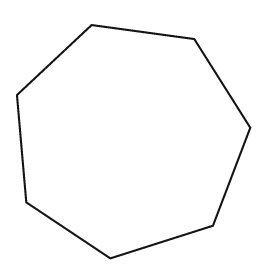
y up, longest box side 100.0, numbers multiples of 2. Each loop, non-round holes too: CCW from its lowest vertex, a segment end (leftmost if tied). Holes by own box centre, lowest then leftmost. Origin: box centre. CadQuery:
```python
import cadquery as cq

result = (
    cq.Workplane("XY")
    .moveTo(-10.0, -50.0)
    .lineTo(34.0, -36.0)
    .lineTo(50.0, 6.0)
    .lineTo(26.0, 44.0)
    .lineTo(-18.0, 50.0)
    .lineTo(-50.0, 20.0)
    .lineTo(-46.0, -26.0)
    .close()
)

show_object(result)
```